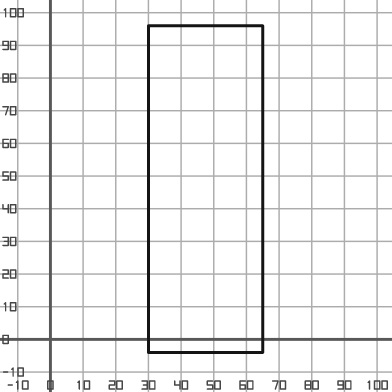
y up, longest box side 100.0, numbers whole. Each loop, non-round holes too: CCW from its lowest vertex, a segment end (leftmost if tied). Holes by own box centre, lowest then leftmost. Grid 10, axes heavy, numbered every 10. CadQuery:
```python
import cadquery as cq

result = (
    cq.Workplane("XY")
    .moveTo(30.0, -4.0)
    .lineTo(65.0, -4.0)
    .lineTo(65.0, 96.0)
    .lineTo(30.0, 96.0)
    .close()
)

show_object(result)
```